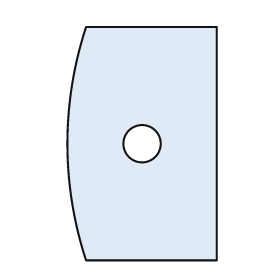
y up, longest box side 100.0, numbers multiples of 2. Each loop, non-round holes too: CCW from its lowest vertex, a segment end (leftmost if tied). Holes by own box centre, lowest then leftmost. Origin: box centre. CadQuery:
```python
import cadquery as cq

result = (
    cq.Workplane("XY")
    .moveTo(-24.0, -50.0)
    .lineTo(32.0, -50.0)
    .lineTo(32.0, 50.0)
    .lineTo(-24.0, 50.0)
    .threePointArc((-32.0, 0.0), (-24.0, -50.0))
    .close()
    .moveTo(0.0, 0.0)
    .circle(8.0)
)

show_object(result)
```